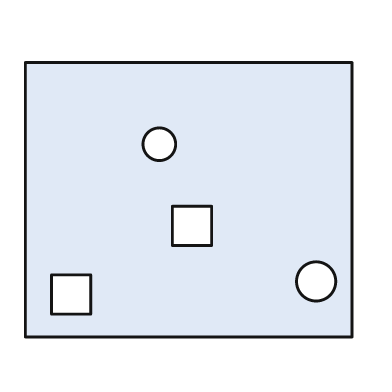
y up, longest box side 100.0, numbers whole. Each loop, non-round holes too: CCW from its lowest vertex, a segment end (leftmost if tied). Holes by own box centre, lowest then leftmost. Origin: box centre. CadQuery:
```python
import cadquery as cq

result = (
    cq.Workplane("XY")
    .moveTo(-50.0, -42.0)
    .lineTo(50.0, -42.0)
    .lineTo(50.0, 42.0)
    .lineTo(-50.0, 42.0)
    .close()
    .moveTo(-42.0, -35.0)
    .lineTo(-30.0, -35.0)
    .lineTo(-30.0, -23.0)
    .lineTo(-42.0, -23.0)
    .close()
    .moveTo(39.0, -25.0)
    .circle(6.0)
    .moveTo(-5.0, -14.0)
    .lineTo(7.0, -14.0)
    .lineTo(7.0, -2.0)
    .lineTo(-5.0, -2.0)
    .close()
    .moveTo(-9.0, 17.0)
    .circle(5.0)
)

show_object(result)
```